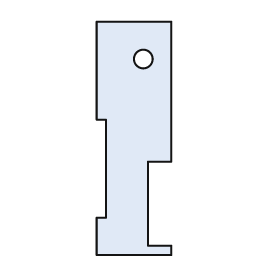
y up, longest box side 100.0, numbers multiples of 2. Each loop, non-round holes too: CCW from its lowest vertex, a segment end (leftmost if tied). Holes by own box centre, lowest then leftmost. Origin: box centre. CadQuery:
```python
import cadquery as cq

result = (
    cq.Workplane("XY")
    .moveTo(-16.0, -50.0)
    .lineTo(16.0, -50.0)
    .lineTo(16.0, -46.0)
    .lineTo(6.0, -46.0)
    .lineTo(6.0, -10.0)
    .lineTo(16.0, -10.0)
    .lineTo(16.0, 50.0)
    .lineTo(-16.0, 50.0)
    .lineTo(-16.0, 8.0)
    .lineTo(-12.0, 8.0)
    .lineTo(-12.0, -34.0)
    .lineTo(-16.0, -34.0)
    .close()
    .moveTo(4.0, 34.0)
    .circle(4.0)
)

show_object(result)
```